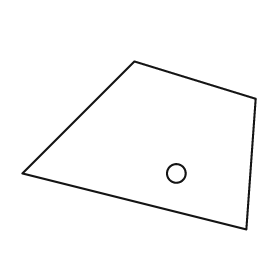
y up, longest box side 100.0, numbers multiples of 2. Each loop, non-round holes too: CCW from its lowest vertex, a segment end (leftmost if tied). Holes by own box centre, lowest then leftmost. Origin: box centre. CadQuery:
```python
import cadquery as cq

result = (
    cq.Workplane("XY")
    .moveTo(46.0, -36.0)
    .lineTo(50.0, 20.0)
    .lineTo(-2.0, 36.0)
    .lineTo(-50.0, -12.0)
    .close()
    .moveTo(16.0, -12.0)
    .circle(4.0)
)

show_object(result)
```